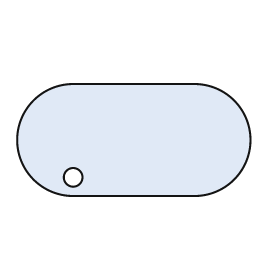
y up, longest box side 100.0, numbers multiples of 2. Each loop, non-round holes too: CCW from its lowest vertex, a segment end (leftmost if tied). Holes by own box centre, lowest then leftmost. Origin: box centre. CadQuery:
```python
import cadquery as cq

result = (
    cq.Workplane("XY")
    .moveTo(-26.0, -24.0)
    .lineTo(26.0, -24.0)
    .threePointArc((50.0, 0.0), (26.0, 24.0))
    .lineTo(-26.0, 24.0)
    .threePointArc((-50.0, 0.0), (-26.0, -24.0))
    .close()
    .moveTo(-26.0, -16.0)
    .circle(4.0)
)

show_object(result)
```